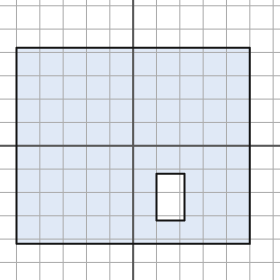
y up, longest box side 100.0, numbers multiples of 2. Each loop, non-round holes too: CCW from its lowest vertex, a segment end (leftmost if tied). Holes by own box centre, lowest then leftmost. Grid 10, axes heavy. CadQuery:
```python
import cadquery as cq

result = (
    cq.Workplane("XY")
    .moveTo(-50.0, -42.0)
    .lineTo(50.0, -42.0)
    .lineTo(50.0, 42.0)
    .lineTo(-50.0, 42.0)
    .close()
    .moveTo(10.0, -32.0)
    .lineTo(22.0, -32.0)
    .lineTo(22.0, -12.0)
    .lineTo(10.0, -12.0)
    .close()
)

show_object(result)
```